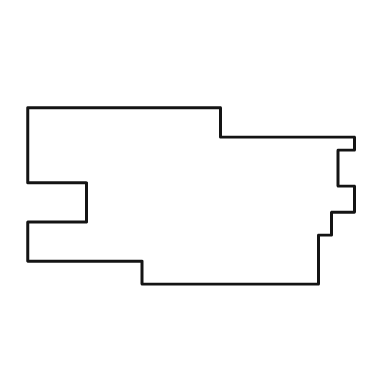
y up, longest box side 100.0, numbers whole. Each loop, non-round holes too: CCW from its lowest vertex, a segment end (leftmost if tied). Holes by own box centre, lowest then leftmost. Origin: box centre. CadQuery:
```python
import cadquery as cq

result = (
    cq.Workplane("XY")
    .moveTo(-15.0, -27.0)
    .lineTo(39.0, -27.0)
    .lineTo(39.0, -12.0)
    .lineTo(43.0, -12.0)
    .lineTo(43.0, -5.0)
    .lineTo(50.0, -5.0)
    .lineTo(50.0, 3.0)
    .lineTo(45.0, 3.0)
    .lineTo(45.0, 14.0)
    .lineTo(50.0, 14.0)
    .lineTo(50.0, 18.0)
    .lineTo(9.0, 18.0)
    .lineTo(9.0, 27.0)
    .lineTo(-50.0, 27.0)
    .lineTo(-50.0, 4.0)
    .lineTo(-32.0, 4.0)
    .lineTo(-32.0, -8.0)
    .lineTo(-50.0, -8.0)
    .lineTo(-50.0, -20.0)
    .lineTo(-15.0, -20.0)
    .close()
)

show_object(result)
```